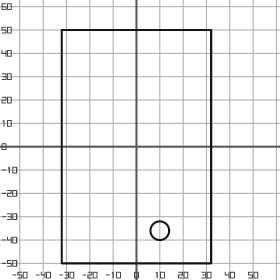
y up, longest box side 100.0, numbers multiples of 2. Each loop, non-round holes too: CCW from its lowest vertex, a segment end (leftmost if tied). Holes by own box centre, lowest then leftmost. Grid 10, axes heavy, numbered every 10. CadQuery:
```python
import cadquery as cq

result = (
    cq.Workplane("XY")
    .moveTo(-32.0, -50.0)
    .lineTo(32.0, -50.0)
    .lineTo(32.0, 50.0)
    .lineTo(-32.0, 50.0)
    .close()
    .moveTo(10.0, -36.0)
    .circle(4.0)
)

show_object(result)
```